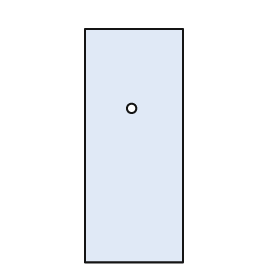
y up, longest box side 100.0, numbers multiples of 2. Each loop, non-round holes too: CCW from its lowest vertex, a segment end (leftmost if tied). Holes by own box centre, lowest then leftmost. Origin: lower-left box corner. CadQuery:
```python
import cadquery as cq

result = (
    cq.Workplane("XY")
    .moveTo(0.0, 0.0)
    .lineTo(42.0, 0.0)
    .lineTo(42.0, 100.0)
    .lineTo(0.0, 100.0)
    .close()
    .moveTo(20.0, 66.0)
    .circle(2.0)
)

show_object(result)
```